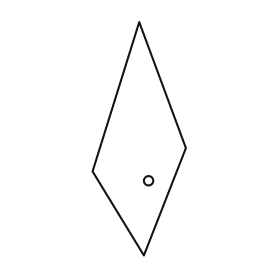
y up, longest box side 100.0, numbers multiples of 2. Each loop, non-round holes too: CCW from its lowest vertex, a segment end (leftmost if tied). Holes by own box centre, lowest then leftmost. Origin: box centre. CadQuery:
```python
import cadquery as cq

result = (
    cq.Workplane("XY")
    .moveTo(2.0, -50.0)
    .lineTo(20.0, -4.0)
    .lineTo(0.0, 50.0)
    .lineTo(-20.0, -14.0)
    .close()
    .moveTo(4.0, -18.0)
    .circle(2.0)
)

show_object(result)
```